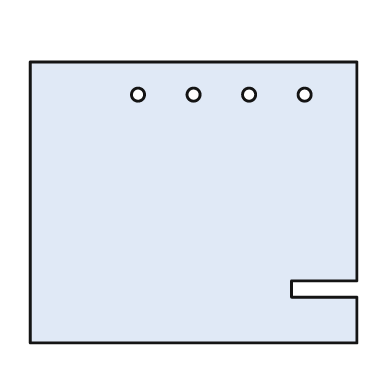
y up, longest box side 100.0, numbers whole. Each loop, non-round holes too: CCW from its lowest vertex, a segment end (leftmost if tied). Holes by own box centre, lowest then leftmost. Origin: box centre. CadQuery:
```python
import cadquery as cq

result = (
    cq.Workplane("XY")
    .moveTo(-50.0, -43.0)
    .lineTo(50.0, -43.0)
    .lineTo(50.0, -29.0)
    .lineTo(30.0, -29.0)
    .lineTo(30.0, -24.0)
    .lineTo(50.0, -24.0)
    .lineTo(50.0, 43.0)
    .lineTo(-50.0, 43.0)
    .close()
    .moveTo(-17.0, 33.0)
    .circle(2.0)
    .moveTo(0.0, 33.0)
    .circle(2.0)
    .moveTo(17.0, 33.0)
    .circle(2.0)
    .moveTo(34.0, 33.0)
    .circle(2.0)
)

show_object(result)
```